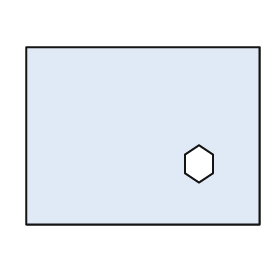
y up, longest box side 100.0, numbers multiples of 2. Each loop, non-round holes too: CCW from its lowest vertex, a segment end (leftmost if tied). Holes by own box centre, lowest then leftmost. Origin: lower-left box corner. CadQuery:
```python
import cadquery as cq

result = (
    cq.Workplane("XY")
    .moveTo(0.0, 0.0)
    .lineTo(100.0, 0.0)
    .lineTo(100.0, 76.0)
    .lineTo(0.0, 76.0)
    .close()
    .moveTo(74.0, 18.0)
    .lineTo(80.0, 22.0)
    .lineTo(80.0, 30.0)
    .lineTo(74.0, 34.0)
    .lineTo(68.0, 30.0)
    .lineTo(68.0, 22.0)
    .close()
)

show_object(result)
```